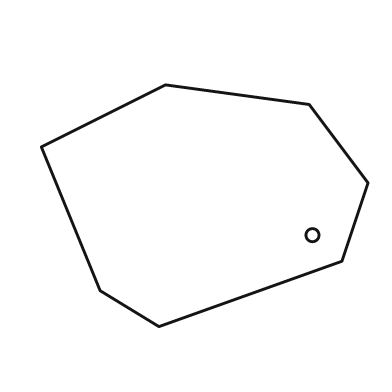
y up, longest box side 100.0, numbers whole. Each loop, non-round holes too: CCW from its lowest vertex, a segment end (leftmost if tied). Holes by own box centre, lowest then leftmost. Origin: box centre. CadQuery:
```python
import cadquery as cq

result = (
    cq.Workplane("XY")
    .moveTo(-14.0, -37.0)
    .lineTo(42.0, -17.0)
    .lineTo(50.0, 7.0)
    .lineTo(32.0, 31.0)
    .lineTo(-12.0, 37.0)
    .lineTo(-50.0, 18.0)
    .lineTo(-32.0, -26.0)
    .close()
    .moveTo(33.0, -9.0)
    .circle(2.0)
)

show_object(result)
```